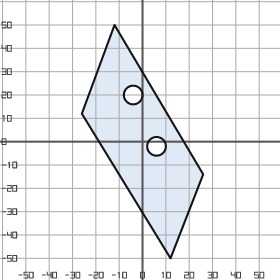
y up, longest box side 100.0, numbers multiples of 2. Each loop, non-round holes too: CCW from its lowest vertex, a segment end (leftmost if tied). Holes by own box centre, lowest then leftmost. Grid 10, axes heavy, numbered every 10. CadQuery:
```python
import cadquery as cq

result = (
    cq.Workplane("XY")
    .moveTo(12.0, -50.0)
    .lineTo(26.0, -14.0)
    .lineTo(-12.0, 50.0)
    .lineTo(-26.0, 12.0)
    .close()
    .moveTo(6.0, -2.0)
    .circle(4.0)
    .moveTo(-4.0, 20.0)
    .circle(4.0)
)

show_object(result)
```